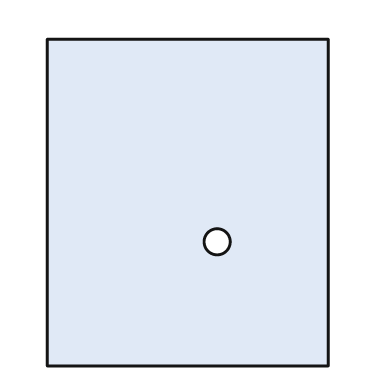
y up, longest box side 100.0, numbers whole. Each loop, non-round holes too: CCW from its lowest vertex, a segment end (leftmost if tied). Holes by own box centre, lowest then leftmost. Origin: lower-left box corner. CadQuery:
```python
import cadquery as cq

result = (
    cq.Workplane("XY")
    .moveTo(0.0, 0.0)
    .lineTo(86.0, 0.0)
    .lineTo(86.0, 100.0)
    .lineTo(0.0, 100.0)
    .close()
    .moveTo(52.0, 38.0)
    .circle(4.0)
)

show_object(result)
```